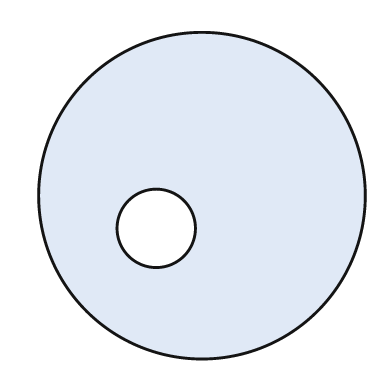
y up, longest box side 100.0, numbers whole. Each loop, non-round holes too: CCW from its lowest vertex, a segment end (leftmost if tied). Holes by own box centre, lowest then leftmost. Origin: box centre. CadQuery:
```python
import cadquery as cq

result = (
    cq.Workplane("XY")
    .moveTo(0.0, 0.0)
    .circle(50.0)
    .moveTo(-14.0, -10.0)
    .circle(12.0)
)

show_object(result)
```